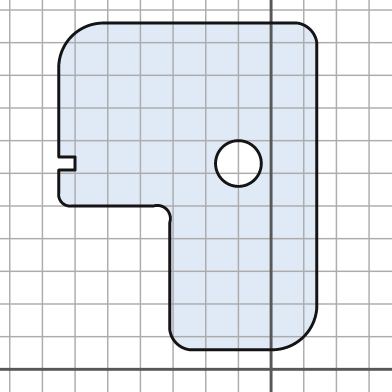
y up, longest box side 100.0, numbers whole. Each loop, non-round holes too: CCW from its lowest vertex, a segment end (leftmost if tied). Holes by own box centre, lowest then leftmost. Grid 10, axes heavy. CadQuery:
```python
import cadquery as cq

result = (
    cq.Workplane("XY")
    .moveTo(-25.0, 6.0)
    .lineTo(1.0, 6.0)
    .threePointArc((10.0, 10.0), (14.0, 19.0))
    .lineTo(14.0, 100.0)
    .threePointArc((12.0, 104.0), (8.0, 106.0))
    .lineTo(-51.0, 106.0)
    .threePointArc((-61.0, 102.0), (-65.0, 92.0))
    .lineTo(-65.0, 65.0)
    .lineTo(-60.0, 65.0)
    .lineTo(-60.0, 61.0)
    .lineTo(-65.0, 61.0)
    .lineTo(-65.0, 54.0)
    .threePointArc((-64.0, 51.0), (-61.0, 50.0))
    .lineTo(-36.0, 50.0)
    .threePointArc((-32.0, 49.0), (-31.0, 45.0))
    .lineTo(-31.0, 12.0)
    .threePointArc((-29.0, 8.0), (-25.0, 6.0))
    .close()
    .moveTo(-10.0, 63.0)
    .circle(7.0)
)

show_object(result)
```